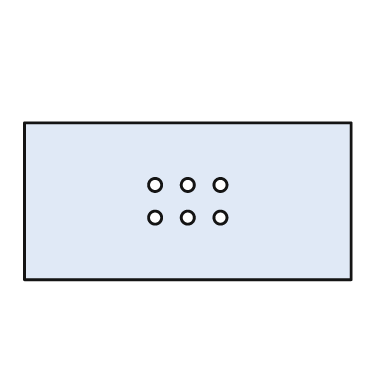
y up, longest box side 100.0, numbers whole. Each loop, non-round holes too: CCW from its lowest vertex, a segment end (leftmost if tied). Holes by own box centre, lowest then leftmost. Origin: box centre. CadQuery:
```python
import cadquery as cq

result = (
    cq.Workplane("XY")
    .moveTo(-50.0, -24.0)
    .lineTo(50.0, -24.0)
    .lineTo(50.0, 24.0)
    .lineTo(-50.0, 24.0)
    .close()
    .moveTo(-10.0, -5.0)
    .circle(2.0)
    .moveTo(0.0, -5.0)
    .circle(2.0)
    .moveTo(10.0, -5.0)
    .circle(2.0)
    .moveTo(-10.0, 5.0)
    .circle(2.0)
    .moveTo(0.0, 5.0)
    .circle(2.0)
    .moveTo(10.0, 5.0)
    .circle(2.0)
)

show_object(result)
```